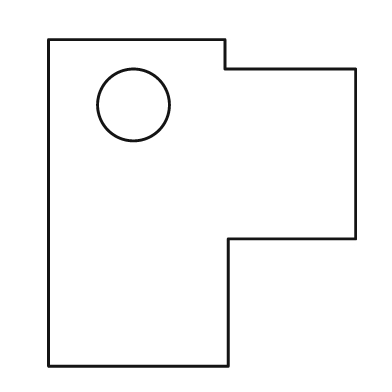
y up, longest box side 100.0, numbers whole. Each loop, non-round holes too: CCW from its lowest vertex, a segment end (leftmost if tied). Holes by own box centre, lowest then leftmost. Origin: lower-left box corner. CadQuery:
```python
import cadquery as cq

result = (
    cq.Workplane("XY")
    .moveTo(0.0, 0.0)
    .lineTo(55.0, 0.0)
    .lineTo(55.0, 39.0)
    .lineTo(94.0, 39.0)
    .lineTo(94.0, 91.0)
    .lineTo(54.0, 91.0)
    .lineTo(54.0, 100.0)
    .lineTo(0.0, 100.0)
    .close()
    .moveTo(26.0, 80.0)
    .circle(11.0)
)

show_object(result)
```